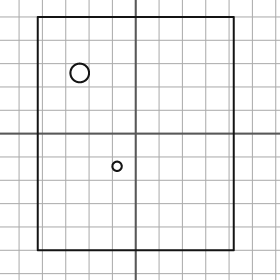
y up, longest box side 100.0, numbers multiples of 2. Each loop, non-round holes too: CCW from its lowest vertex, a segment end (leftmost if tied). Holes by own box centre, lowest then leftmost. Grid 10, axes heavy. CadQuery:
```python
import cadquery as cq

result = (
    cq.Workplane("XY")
    .moveTo(-42.0, -50.0)
    .lineTo(42.0, -50.0)
    .lineTo(42.0, 50.0)
    .lineTo(-42.0, 50.0)
    .close()
    .moveTo(-8.0, -14.0)
    .circle(2.0)
    .moveTo(-24.0, 26.0)
    .circle(4.0)
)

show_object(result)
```